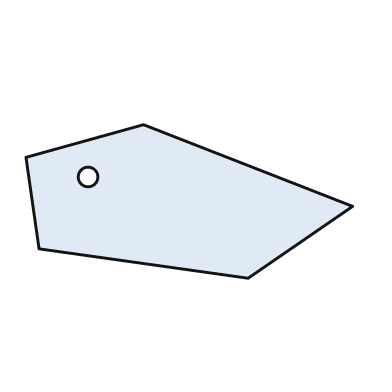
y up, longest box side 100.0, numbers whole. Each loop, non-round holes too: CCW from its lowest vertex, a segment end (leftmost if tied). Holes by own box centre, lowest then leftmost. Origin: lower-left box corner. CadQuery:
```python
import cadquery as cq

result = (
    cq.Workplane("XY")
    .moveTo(68.0, 0.0)
    .lineTo(100.0, 22.0)
    .lineTo(36.0, 47.0)
    .lineTo(0.0, 37.0)
    .lineTo(4.0, 9.0)
    .close()
    .moveTo(19.0, 31.0)
    .circle(3.0)
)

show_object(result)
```